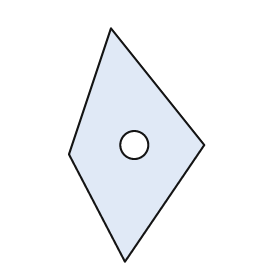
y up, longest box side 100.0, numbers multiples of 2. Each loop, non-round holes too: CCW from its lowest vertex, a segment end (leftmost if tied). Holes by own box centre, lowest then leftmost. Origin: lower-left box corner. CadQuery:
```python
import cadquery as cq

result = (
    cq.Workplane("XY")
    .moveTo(24.0, 0.0)
    .lineTo(58.0, 50.0)
    .lineTo(18.0, 100.0)
    .lineTo(0.0, 46.0)
    .close()
    .moveTo(28.0, 50.0)
    .circle(6.0)
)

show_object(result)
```